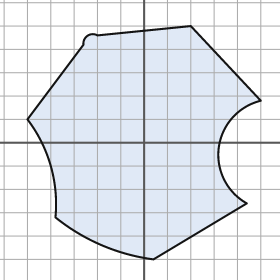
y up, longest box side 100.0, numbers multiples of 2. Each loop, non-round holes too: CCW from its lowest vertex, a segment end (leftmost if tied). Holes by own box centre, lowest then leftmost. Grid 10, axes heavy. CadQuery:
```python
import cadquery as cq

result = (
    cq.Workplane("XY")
    .moveTo(4.0, -50.0)
    .lineTo(44.0, -26.0)
    .threePointArc((32.0, -2.0), (50.0, 18.0))
    .lineTo(20.0, 50.0)
    .lineTo(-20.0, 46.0)
    .threePointArc((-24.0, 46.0), (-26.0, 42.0))
    .lineTo(-50.0, 10.0)
    .threePointArc((-40.0, -10.0), (-38.0, -32.0))
    .threePointArc((-18.0, -44.0), (4.0, -50.0))
    .close()
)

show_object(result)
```